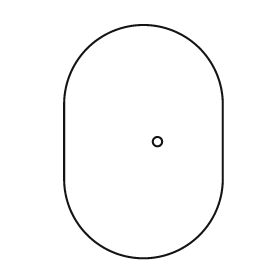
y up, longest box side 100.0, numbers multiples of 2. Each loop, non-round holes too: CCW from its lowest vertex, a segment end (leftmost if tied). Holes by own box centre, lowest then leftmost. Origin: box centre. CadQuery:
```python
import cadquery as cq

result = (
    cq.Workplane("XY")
    .moveTo(-34.0, -16.0)
    .threePointArc((0.0, -50.0), (34.0, -16.0))
    .lineTo(34.0, 16.0)
    .threePointArc((0.0, 50.0), (-34.0, 16.0))
    .close()
    .moveTo(6.0, 0.0)
    .circle(2.0)
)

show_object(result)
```